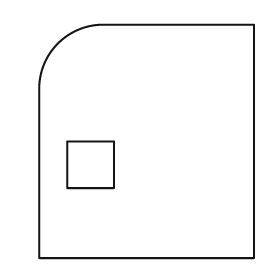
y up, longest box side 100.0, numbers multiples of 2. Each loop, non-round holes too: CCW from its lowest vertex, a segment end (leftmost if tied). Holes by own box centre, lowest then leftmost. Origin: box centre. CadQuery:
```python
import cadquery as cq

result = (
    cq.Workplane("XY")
    .moveTo(-46.0, -50.0)
    .lineTo(46.0, -50.0)
    .lineTo(46.0, 50.0)
    .lineTo(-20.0, 50.0)
    .threePointArc((-38.0, 42.0), (-46.0, 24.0))
    .close()
    .moveTo(-34.0, -20.0)
    .lineTo(-14.0, -20.0)
    .lineTo(-14.0, 0.0)
    .lineTo(-34.0, 0.0)
    .close()
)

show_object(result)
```